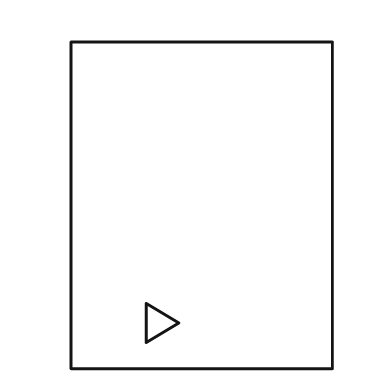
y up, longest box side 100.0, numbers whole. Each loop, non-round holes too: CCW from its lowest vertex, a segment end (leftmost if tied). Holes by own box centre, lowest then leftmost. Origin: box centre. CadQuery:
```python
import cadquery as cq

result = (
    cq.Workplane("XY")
    .moveTo(-40.0, -50.0)
    .lineTo(40.0, -50.0)
    .lineTo(40.0, 50.0)
    .lineTo(-40.0, 50.0)
    .close()
    .moveTo(-17.0, -42.0)
    .lineTo(-7.0, -36.0)
    .lineTo(-17.0, -30.0)
    .close()
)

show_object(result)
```